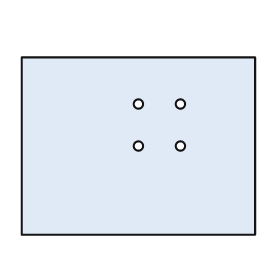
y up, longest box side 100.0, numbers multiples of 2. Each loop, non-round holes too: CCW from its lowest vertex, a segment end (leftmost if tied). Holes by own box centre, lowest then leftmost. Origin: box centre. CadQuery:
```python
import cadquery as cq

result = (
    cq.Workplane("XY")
    .moveTo(-50.0, -38.0)
    .lineTo(50.0, -38.0)
    .lineTo(50.0, 38.0)
    .lineTo(-50.0, 38.0)
    .close()
    .moveTo(0.0, 0.0)
    .circle(2.0)
    .moveTo(18.0, 0.0)
    .circle(2.0)
    .moveTo(0.0, 18.0)
    .circle(2.0)
    .moveTo(18.0, 18.0)
    .circle(2.0)
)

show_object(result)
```